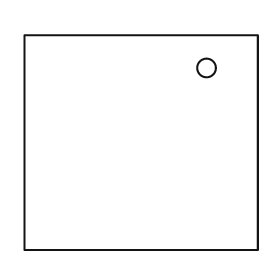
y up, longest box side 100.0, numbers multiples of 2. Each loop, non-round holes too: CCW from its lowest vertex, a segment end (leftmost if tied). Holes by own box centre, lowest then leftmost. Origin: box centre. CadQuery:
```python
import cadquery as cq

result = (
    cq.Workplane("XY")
    .moveTo(-50.0, -46.0)
    .lineTo(50.0, -46.0)
    .lineTo(50.0, 46.0)
    .lineTo(-50.0, 46.0)
    .close()
    .moveTo(28.0, 32.0)
    .circle(4.0)
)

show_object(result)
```